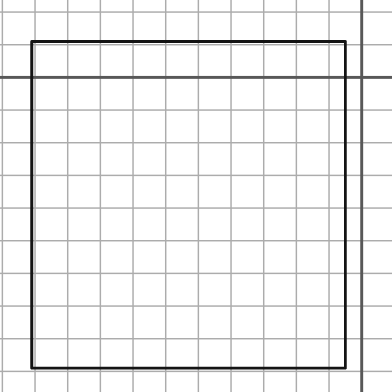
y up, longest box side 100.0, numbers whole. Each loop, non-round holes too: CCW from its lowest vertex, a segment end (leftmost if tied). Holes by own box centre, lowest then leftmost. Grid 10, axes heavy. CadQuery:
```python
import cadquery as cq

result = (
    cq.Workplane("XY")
    .moveTo(-101.0, -89.0)
    .lineTo(-5.0, -89.0)
    .lineTo(-5.0, 11.0)
    .lineTo(-101.0, 11.0)
    .close()
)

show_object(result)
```